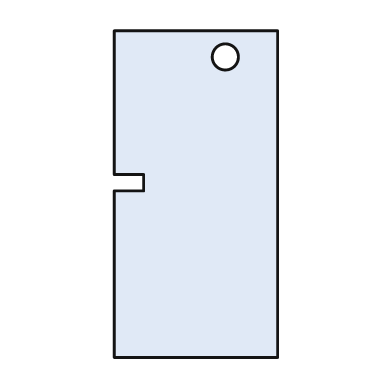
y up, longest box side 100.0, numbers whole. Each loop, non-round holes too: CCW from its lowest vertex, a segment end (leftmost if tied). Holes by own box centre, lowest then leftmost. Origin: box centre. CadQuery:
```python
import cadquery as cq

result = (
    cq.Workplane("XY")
    .moveTo(-25.0, -50.0)
    .lineTo(25.0, -50.0)
    .lineTo(25.0, 50.0)
    .lineTo(-25.0, 50.0)
    .lineTo(-25.0, 6.0)
    .lineTo(-16.0, 6.0)
    .lineTo(-16.0, 1.0)
    .lineTo(-25.0, 1.0)
    .close()
    .moveTo(9.0, 42.0)
    .circle(4.0)
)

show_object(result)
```